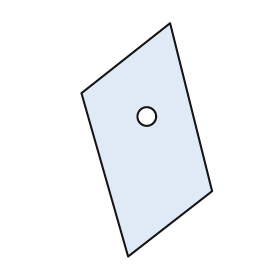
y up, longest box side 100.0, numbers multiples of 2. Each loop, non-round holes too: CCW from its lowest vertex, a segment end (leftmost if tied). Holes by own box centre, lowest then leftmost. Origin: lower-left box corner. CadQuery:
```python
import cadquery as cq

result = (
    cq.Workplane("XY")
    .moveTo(20.0, 0.0)
    .lineTo(56.0, 28.0)
    .lineTo(38.0, 100.0)
    .lineTo(0.0, 70.0)
    .close()
    .moveTo(28.0, 60.0)
    .circle(4.0)
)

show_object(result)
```